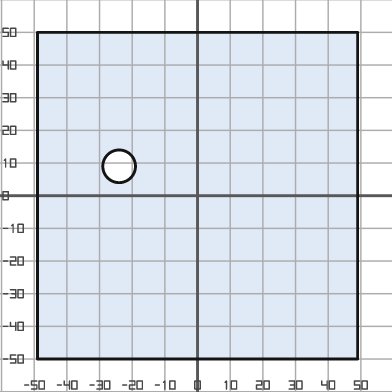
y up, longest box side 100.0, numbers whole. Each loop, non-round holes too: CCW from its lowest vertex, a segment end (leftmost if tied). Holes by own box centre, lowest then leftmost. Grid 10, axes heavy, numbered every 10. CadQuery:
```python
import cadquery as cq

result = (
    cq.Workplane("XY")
    .moveTo(-49.0, -50.0)
    .lineTo(49.0, -50.0)
    .lineTo(49.0, 50.0)
    .lineTo(-49.0, 50.0)
    .close()
    .moveTo(-24.0, 9.0)
    .circle(5.0)
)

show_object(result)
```